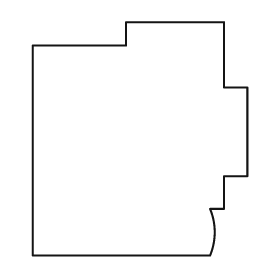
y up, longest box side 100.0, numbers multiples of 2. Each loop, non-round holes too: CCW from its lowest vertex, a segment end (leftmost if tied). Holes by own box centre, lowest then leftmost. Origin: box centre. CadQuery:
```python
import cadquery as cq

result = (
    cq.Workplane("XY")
    .moveTo(-46.0, -50.0)
    .lineTo(30.0, -50.0)
    .threePointArc((32.0, -40.0), (30.0, -30.0))
    .lineTo(36.0, -30.0)
    .lineTo(36.0, -16.0)
    .lineTo(46.0, -16.0)
    .lineTo(46.0, 22.0)
    .lineTo(36.0, 22.0)
    .lineTo(36.0, 50.0)
    .lineTo(-6.0, 50.0)
    .lineTo(-6.0, 40.0)
    .lineTo(-46.0, 40.0)
    .close()
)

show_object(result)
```